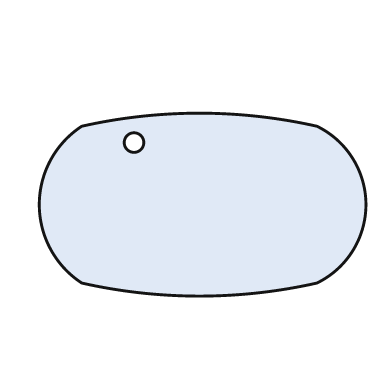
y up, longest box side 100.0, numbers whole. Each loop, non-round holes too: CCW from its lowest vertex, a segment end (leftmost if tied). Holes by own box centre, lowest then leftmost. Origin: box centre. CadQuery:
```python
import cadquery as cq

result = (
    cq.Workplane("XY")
    .moveTo(-37.0, -24.0)
    .threePointArc((-1.0, -28.0), (35.0, -24.0))
    .threePointArc((50.0, 0.0), (35.0, 24.0))
    .threePointArc((-1.0, 28.0), (-37.0, 24.0))
    .threePointArc((-50.0, 0.0), (-37.0, -24.0))
    .close()
    .moveTo(-21.0, 19.0)
    .circle(3.0)
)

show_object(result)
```